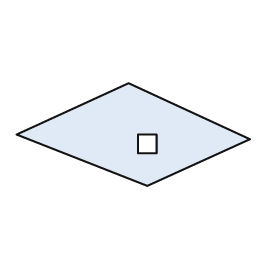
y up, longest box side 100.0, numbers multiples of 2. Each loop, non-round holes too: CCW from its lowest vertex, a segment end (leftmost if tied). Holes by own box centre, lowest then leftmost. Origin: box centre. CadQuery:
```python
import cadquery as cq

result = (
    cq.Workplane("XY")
    .moveTo(6.0, -22.0)
    .lineTo(50.0, -2.0)
    .lineTo(-2.0, 22.0)
    .lineTo(-50.0, 0.0)
    .close()
    .moveTo(2.0, -8.0)
    .lineTo(10.0, -8.0)
    .lineTo(10.0, 0.0)
    .lineTo(2.0, 0.0)
    .close()
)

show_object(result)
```